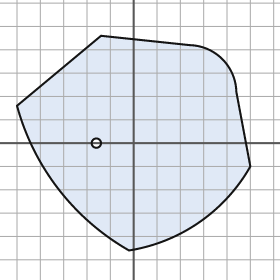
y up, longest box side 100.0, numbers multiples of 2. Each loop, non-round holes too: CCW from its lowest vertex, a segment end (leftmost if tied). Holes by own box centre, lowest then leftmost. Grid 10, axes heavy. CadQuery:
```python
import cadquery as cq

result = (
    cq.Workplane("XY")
    .moveTo(-2.0, -46.0)
    .threePointArc((28.0, -34.0), (50.0, -10.0))
    .lineTo(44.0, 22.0)
    .threePointArc((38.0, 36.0), (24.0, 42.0))
    .lineTo(-14.0, 46.0)
    .lineTo(-50.0, 16.0)
    .threePointArc((-32.0, -20.0), (-2.0, -46.0))
    .close()
    .moveTo(-16.0, 0.0)
    .circle(2.0)
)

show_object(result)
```